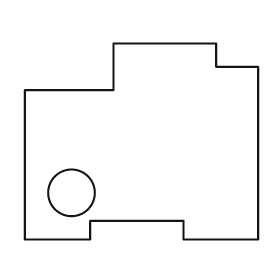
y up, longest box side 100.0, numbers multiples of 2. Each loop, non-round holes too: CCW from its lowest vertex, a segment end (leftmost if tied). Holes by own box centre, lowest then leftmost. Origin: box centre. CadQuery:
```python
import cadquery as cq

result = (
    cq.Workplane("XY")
    .moveTo(-50.0, -42.0)
    .lineTo(-22.0, -42.0)
    .lineTo(-22.0, -34.0)
    .lineTo(18.0, -34.0)
    .lineTo(18.0, -42.0)
    .lineTo(50.0, -42.0)
    .lineTo(50.0, 32.0)
    .lineTo(32.0, 32.0)
    .lineTo(32.0, 42.0)
    .lineTo(-12.0, 42.0)
    .lineTo(-12.0, 22.0)
    .lineTo(-50.0, 22.0)
    .close()
    .moveTo(-30.0, -22.0)
    .circle(10.0)
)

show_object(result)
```